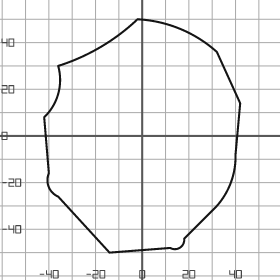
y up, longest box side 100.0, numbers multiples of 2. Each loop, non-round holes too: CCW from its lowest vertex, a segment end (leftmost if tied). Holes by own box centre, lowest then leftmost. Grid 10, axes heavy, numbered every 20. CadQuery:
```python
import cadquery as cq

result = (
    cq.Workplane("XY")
    .moveTo(-14.0, -50.0)
    .lineTo(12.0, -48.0)
    .threePointArc((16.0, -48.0), (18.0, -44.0))
    .lineTo(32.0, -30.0)
    .threePointArc((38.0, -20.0), (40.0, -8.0))
    .lineTo(42.0, 14.0)
    .lineTo(32.0, 36.0)
    .threePointArc((16.0, 46.0), (-2.0, 50.0))
    .threePointArc((-18.0, 38.0), (-36.0, 30.0))
    .threePointArc((-36.0, 18.0), (-42.0, 8.0))
    .lineTo(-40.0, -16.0)
    .threePointArc((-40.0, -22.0), (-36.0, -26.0))
    .close()
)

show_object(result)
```